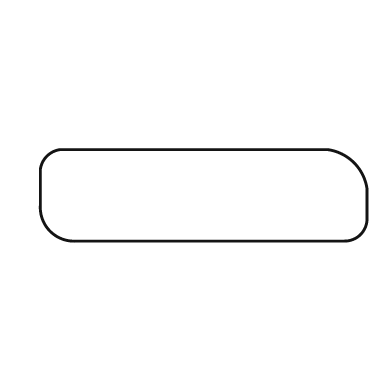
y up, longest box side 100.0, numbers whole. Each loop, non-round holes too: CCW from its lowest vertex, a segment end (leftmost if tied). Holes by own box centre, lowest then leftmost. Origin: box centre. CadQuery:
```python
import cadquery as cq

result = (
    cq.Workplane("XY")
    .moveTo(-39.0, -14.0)
    .lineTo(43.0, -14.0)
    .threePointArc((48.0, -12.0), (50.0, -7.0))
    .lineTo(50.0, 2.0)
    .threePointArc((46.0, 10.0), (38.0, 14.0))
    .lineTo(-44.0, 14.0)
    .threePointArc((-48.0, 12.0), (-50.0, 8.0))
    .lineTo(-50.0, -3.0)
    .threePointArc((-47.0, -11.0), (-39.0, -14.0))
    .close()
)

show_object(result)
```